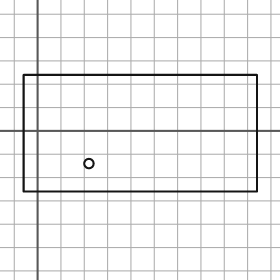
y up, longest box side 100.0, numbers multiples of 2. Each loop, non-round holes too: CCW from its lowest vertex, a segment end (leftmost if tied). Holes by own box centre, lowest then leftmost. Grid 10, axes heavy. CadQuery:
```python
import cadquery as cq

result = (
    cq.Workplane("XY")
    .moveTo(-6.0, -26.0)
    .lineTo(94.0, -26.0)
    .lineTo(94.0, 24.0)
    .lineTo(-6.0, 24.0)
    .close()
    .moveTo(22.0, -14.0)
    .circle(2.0)
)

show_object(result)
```